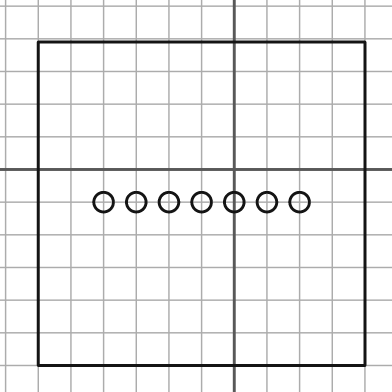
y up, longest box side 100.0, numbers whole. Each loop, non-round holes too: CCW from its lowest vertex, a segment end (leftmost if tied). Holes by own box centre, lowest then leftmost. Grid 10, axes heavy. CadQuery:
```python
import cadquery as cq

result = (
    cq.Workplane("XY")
    .moveTo(-60.0, -60.0)
    .lineTo(40.0, -60.0)
    .lineTo(40.0, 39.0)
    .lineTo(-60.0, 39.0)
    .close()
    .moveTo(-40.0, -10.0)
    .circle(3.0)
    .moveTo(-30.0, -10.0)
    .circle(3.0)
    .moveTo(-20.0, -10.0)
    .circle(3.0)
    .moveTo(-10.0, -10.0)
    .circle(3.0)
    .moveTo(0.0, -10.0)
    .circle(3.0)
    .moveTo(10.0, -10.0)
    .circle(3.0)
    .moveTo(20.0, -10.0)
    .circle(3.0)
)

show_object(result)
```